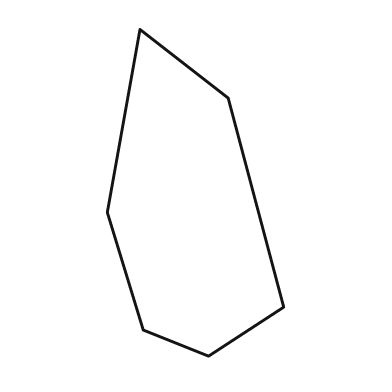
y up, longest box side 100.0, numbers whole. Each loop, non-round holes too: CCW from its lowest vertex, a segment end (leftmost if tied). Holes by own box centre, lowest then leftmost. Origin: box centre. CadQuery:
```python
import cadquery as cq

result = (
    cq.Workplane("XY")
    .moveTo(4.0, -50.0)
    .lineTo(27.0, -35.0)
    .lineTo(10.0, 29.0)
    .lineTo(-17.0, 50.0)
    .lineTo(-27.0, -6.0)
    .lineTo(-16.0, -42.0)
    .close()
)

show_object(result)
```